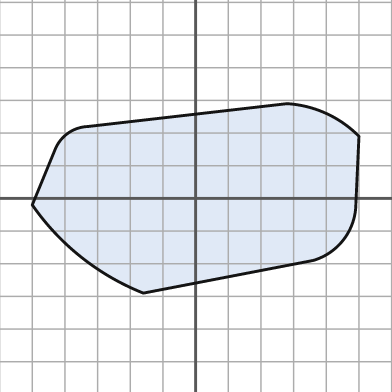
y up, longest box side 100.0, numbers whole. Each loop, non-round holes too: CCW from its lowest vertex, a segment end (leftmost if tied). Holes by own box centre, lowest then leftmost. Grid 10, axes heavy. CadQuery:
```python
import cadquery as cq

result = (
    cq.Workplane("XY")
    .moveTo(-16.0, -29.0)
    .lineTo(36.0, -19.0)
    .threePointArc((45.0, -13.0), (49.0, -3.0))
    .lineTo(50.0, 19.0)
    .threePointArc((40.0, 26.0), (28.0, 29.0))
    .lineTo(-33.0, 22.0)
    .threePointArc((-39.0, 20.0), (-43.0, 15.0))
    .lineTo(-50.0, -2.0)
    .threePointArc((-35.0, -18.0), (-16.0, -29.0))
    .close()
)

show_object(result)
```